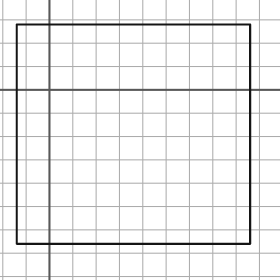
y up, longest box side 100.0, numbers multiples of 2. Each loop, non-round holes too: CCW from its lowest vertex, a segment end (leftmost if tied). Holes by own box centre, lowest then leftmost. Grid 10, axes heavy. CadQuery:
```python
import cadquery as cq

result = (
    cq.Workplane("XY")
    .moveTo(-14.0, -66.0)
    .lineTo(86.0, -66.0)
    .lineTo(86.0, 28.0)
    .lineTo(-14.0, 28.0)
    .close()
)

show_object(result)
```